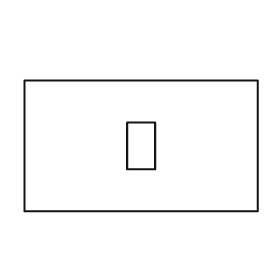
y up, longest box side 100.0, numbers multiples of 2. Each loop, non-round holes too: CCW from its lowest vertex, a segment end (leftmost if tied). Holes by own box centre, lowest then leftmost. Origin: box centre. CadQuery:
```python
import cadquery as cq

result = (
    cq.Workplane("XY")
    .moveTo(-50.0, -28.0)
    .lineTo(50.0, -28.0)
    .lineTo(50.0, 28.0)
    .lineTo(-50.0, 28.0)
    .close()
    .moveTo(-6.0, -10.0)
    .lineTo(6.0, -10.0)
    .lineTo(6.0, 10.0)
    .lineTo(-6.0, 10.0)
    .close()
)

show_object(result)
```